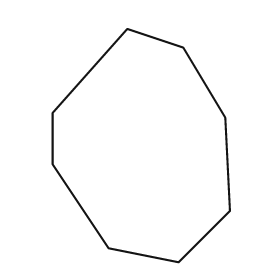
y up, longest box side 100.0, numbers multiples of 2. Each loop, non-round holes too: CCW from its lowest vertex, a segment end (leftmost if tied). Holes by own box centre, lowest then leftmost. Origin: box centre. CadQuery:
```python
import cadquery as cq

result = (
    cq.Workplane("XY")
    .moveTo(16.0, -50.0)
    .lineTo(38.0, -28.0)
    .lineTo(36.0, 12.0)
    .lineTo(18.0, 42.0)
    .lineTo(-6.0, 50.0)
    .lineTo(-38.0, 14.0)
    .lineTo(-38.0, -8.0)
    .lineTo(-14.0, -44.0)
    .close()
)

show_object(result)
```